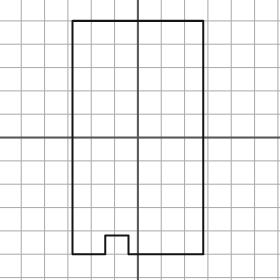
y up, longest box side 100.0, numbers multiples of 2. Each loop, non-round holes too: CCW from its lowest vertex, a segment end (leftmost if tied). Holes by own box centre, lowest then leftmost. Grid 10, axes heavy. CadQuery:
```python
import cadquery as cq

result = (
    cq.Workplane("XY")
    .moveTo(-28.0, -50.0)
    .lineTo(-14.0, -50.0)
    .lineTo(-14.0, -42.0)
    .lineTo(-4.0, -42.0)
    .lineTo(-4.0, -50.0)
    .lineTo(28.0, -50.0)
    .lineTo(28.0, 50.0)
    .lineTo(-28.0, 50.0)
    .close()
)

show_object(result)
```